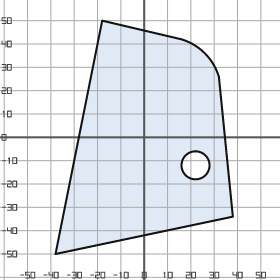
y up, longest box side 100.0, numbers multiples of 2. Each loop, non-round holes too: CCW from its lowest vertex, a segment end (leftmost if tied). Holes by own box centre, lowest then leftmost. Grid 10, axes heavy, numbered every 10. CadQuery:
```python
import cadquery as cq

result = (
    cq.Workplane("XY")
    .moveTo(-38.0, -50.0)
    .lineTo(38.0, -34.0)
    .lineTo(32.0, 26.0)
    .threePointArc((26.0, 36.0), (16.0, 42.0))
    .lineTo(-18.0, 50.0)
    .close()
    .moveTo(22.0, -12.0)
    .circle(6.0)
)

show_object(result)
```